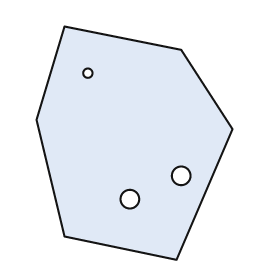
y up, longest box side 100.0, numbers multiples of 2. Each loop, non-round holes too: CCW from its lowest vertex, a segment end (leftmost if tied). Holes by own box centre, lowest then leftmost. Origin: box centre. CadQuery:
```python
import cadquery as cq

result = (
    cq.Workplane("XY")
    .moveTo(18.0, -50.0)
    .lineTo(42.0, 6.0)
    .lineTo(20.0, 40.0)
    .lineTo(-30.0, 50.0)
    .lineTo(-42.0, 10.0)
    .lineTo(-30.0, -40.0)
    .close()
    .moveTo(-2.0, -24.0)
    .circle(4.0)
    .moveTo(20.0, -14.0)
    .circle(4.0)
    .moveTo(-20.0, 30.0)
    .circle(2.0)
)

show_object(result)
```